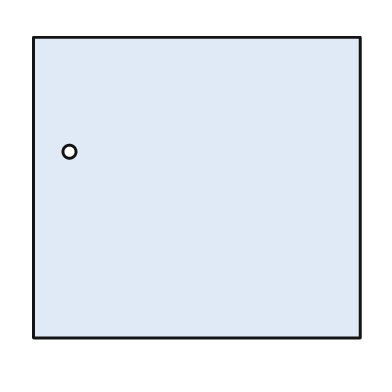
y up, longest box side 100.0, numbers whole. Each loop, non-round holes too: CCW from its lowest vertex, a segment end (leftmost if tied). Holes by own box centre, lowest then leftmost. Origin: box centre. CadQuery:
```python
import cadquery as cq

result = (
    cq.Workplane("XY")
    .moveTo(-50.0, -46.0)
    .lineTo(50.0, -46.0)
    .lineTo(50.0, 46.0)
    .lineTo(-50.0, 46.0)
    .close()
    .moveTo(-39.0, 11.0)
    .circle(2.0)
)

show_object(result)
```